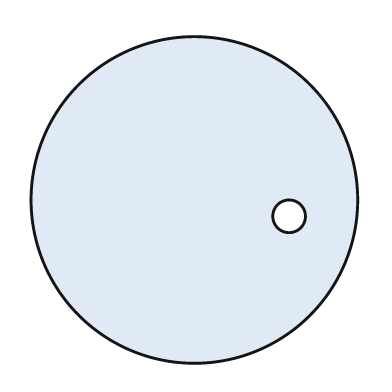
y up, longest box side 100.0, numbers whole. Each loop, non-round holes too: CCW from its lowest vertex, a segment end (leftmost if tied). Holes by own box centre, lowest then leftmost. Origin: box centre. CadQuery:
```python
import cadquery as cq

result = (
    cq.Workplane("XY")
    .moveTo(0.0, 0.0)
    .circle(50.0)
    .moveTo(29.0, -5.0)
    .circle(5.0)
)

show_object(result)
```